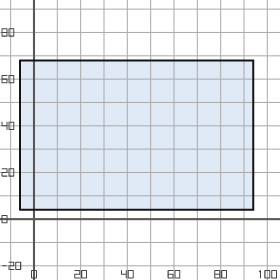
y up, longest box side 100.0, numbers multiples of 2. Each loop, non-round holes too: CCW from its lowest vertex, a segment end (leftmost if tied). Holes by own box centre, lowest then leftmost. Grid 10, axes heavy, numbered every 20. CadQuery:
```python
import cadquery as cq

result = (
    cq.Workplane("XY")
    .moveTo(-6.0, 4.0)
    .lineTo(94.0, 4.0)
    .lineTo(94.0, 68.0)
    .lineTo(-6.0, 68.0)
    .close()
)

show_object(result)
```